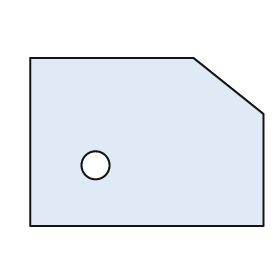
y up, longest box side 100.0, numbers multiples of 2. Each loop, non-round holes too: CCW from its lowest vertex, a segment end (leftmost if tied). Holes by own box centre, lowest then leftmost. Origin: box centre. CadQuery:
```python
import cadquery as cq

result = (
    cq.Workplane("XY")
    .moveTo(-50.0, -36.0)
    .lineTo(50.0, -36.0)
    .lineTo(50.0, 12.0)
    .lineTo(20.0, 36.0)
    .lineTo(-50.0, 36.0)
    .close()
    .moveTo(-22.0, -10.0)
    .circle(6.0)
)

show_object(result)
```